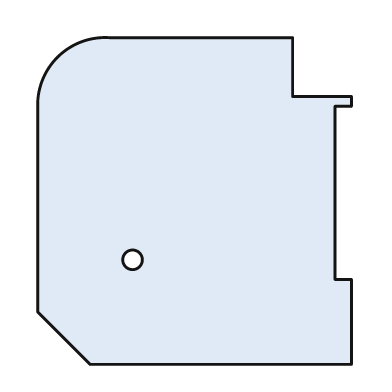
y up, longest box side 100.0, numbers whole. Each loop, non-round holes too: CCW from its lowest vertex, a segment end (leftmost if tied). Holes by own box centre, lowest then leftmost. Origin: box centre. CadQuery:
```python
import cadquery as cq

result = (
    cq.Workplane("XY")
    .moveTo(-32.0, -50.0)
    .lineTo(48.0, -50.0)
    .lineTo(48.0, -24.0)
    .lineTo(43.0, -24.0)
    .lineTo(43.0, 29.0)
    .lineTo(48.0, 29.0)
    .lineTo(48.0, 32.0)
    .lineTo(30.0, 32.0)
    .lineTo(30.0, 50.0)
    .lineTo(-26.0, 50.0)
    .threePointArc((-42.0, 44.0), (-48.0, 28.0))
    .lineTo(-48.0, -34.0)
    .close()
    .moveTo(-19.0, -18.0)
    .circle(3.0)
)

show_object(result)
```